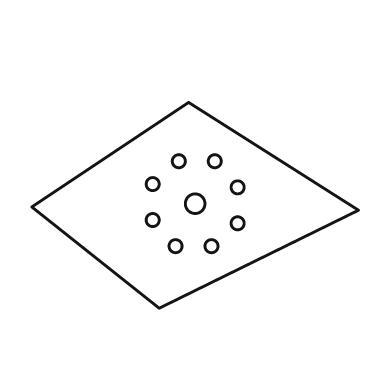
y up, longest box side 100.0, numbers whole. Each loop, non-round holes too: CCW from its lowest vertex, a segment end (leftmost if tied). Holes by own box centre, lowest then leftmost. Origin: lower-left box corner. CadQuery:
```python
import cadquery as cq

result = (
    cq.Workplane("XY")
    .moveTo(39.0, 0.0)
    .lineTo(100.0, 30.0)
    .lineTo(48.0, 63.0)
    .lineTo(0.0, 31.0)
    .close()
    .moveTo(44.0, 19.0)
    .circle(2.0)
    .moveTo(55.0, 19.0)
    .circle(2.0)
    .moveTo(63.0, 26.0)
    .circle(2.0)
    .moveTo(37.0, 27.0)
    .circle(2.0)
    .moveTo(50.0, 32.0)
    .circle(3.0)
    .moveTo(63.0, 37.0)
    .circle(2.0)
    .moveTo(37.0, 38.0)
    .circle(2.0)
    .moveTo(45.0, 45.0)
    .circle(2.0)
    .moveTo(56.0, 45.0)
    .circle(2.0)
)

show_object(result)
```